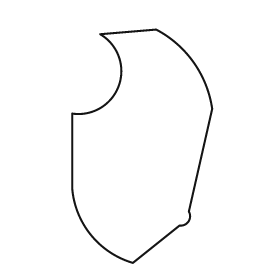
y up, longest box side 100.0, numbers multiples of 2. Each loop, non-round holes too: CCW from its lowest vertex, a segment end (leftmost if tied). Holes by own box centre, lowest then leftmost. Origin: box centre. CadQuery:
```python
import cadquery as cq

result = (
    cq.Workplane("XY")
    .moveTo(-4.0, -50.0)
    .lineTo(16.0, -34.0)
    .threePointArc((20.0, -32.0), (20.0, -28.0))
    .lineTo(30.0, 16.0)
    .threePointArc((22.0, 36.0), (6.0, 50.0))
    .lineTo(-18.0, 48.0)
    .threePointArc((-10.0, 26.0), (-30.0, 14.0))
    .lineTo(-30.0, -18.0)
    .threePointArc((-22.0, -38.0), (-4.0, -50.0))
    .close()
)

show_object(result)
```